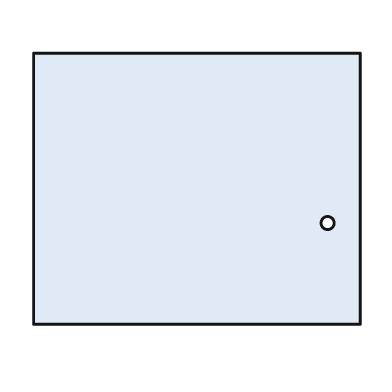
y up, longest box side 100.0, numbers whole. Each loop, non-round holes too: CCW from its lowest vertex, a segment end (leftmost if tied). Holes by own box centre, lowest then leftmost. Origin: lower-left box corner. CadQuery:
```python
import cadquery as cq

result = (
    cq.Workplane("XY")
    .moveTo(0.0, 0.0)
    .lineTo(100.0, 0.0)
    .lineTo(100.0, 83.0)
    .lineTo(0.0, 83.0)
    .close()
    .moveTo(90.0, 31.0)
    .circle(2.0)
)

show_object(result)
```